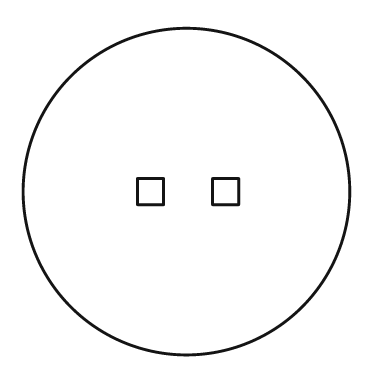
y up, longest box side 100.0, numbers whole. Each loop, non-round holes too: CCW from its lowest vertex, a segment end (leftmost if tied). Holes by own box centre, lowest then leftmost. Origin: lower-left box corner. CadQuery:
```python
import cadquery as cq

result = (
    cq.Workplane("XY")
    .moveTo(50.0, 50.0)
    .circle(50.0)
    .moveTo(35.0, 46.0)
    .lineTo(43.0, 46.0)
    .lineTo(43.0, 54.0)
    .lineTo(35.0, 54.0)
    .close()
    .moveTo(58.0, 46.0)
    .lineTo(66.0, 46.0)
    .lineTo(66.0, 54.0)
    .lineTo(58.0, 54.0)
    .close()
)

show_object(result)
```